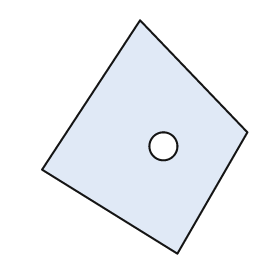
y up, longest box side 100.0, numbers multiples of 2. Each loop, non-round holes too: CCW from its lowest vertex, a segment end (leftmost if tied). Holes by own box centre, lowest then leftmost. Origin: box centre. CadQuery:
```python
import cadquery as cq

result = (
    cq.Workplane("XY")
    .moveTo(14.0, -50.0)
    .lineTo(44.0, 2.0)
    .lineTo(-2.0, 50.0)
    .lineTo(-44.0, -14.0)
    .close()
    .moveTo(8.0, -4.0)
    .circle(6.0)
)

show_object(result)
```